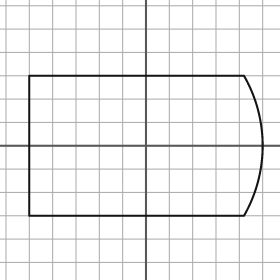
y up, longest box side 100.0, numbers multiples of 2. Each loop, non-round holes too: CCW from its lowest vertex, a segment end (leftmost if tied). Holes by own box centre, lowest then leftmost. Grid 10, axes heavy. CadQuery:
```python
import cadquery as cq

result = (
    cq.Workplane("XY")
    .moveTo(-50.0, -30.0)
    .lineTo(42.0, -30.0)
    .threePointArc((50.0, 0.0), (42.0, 30.0))
    .lineTo(-50.0, 30.0)
    .close()
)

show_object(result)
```